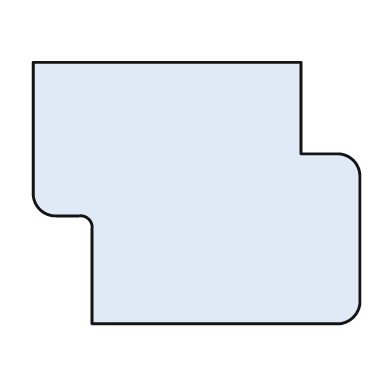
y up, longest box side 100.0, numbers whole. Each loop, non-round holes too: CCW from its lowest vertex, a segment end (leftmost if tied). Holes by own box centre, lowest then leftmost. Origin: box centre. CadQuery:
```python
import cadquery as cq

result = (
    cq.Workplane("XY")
    .moveTo(-32.0, -40.0)
    .lineTo(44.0, -40.0)
    .threePointArc((48.0, -38.0), (50.0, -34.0))
    .lineTo(50.0, 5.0)
    .threePointArc((48.0, 10.0), (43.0, 12.0))
    .lineTo(32.0, 12.0)
    .lineTo(32.0, 40.0)
    .lineTo(-50.0, 40.0)
    .lineTo(-50.0, 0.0)
    .threePointArc((-48.0, -5.0), (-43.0, -7.0))
    .lineTo(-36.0, -7.0)
    .threePointArc((-33.0, -8.0), (-32.0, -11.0))
    .close()
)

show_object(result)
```